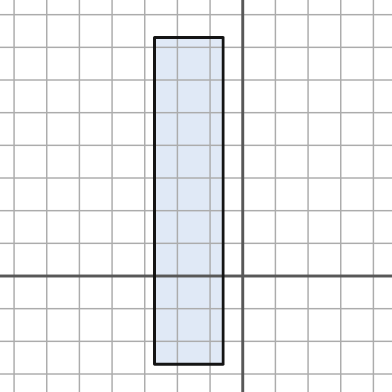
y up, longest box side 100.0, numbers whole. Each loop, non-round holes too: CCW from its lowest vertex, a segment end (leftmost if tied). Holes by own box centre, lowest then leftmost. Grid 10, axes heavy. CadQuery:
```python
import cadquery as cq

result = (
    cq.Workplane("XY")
    .moveTo(-27.0, -27.0)
    .lineTo(-6.0, -27.0)
    .lineTo(-6.0, 73.0)
    .lineTo(-27.0, 73.0)
    .close()
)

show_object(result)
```